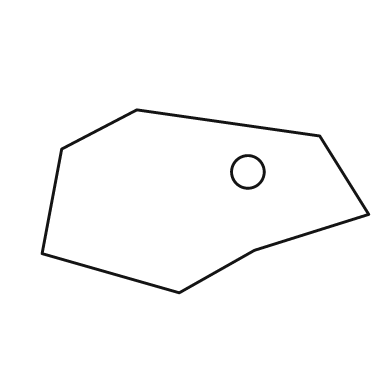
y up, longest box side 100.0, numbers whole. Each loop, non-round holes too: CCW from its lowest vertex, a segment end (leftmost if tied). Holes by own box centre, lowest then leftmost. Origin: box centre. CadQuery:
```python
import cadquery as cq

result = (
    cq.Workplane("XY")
    .moveTo(-8.0, -28.0)
    .lineTo(15.0, -15.0)
    .lineTo(50.0, -4.0)
    .lineTo(35.0, 20.0)
    .lineTo(-21.0, 28.0)
    .lineTo(-44.0, 16.0)
    .lineTo(-50.0, -16.0)
    .close()
    .moveTo(13.0, 9.0)
    .circle(5.0)
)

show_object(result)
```